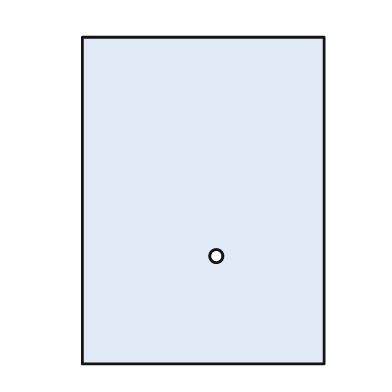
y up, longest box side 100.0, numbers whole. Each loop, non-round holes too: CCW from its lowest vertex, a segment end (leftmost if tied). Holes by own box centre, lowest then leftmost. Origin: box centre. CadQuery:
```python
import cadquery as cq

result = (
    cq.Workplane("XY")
    .moveTo(-37.0, -50.0)
    .lineTo(37.0, -50.0)
    .lineTo(37.0, 50.0)
    .lineTo(-37.0, 50.0)
    .close()
    .moveTo(4.0, -17.0)
    .circle(2.0)
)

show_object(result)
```